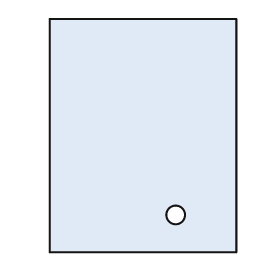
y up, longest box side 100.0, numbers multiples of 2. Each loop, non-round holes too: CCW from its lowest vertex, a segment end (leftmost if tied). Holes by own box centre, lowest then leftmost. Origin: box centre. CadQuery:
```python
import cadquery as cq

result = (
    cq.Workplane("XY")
    .moveTo(-40.0, -50.0)
    .lineTo(40.0, -50.0)
    .lineTo(40.0, 50.0)
    .lineTo(-40.0, 50.0)
    .close()
    .moveTo(14.0, -34.0)
    .circle(4.0)
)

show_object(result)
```